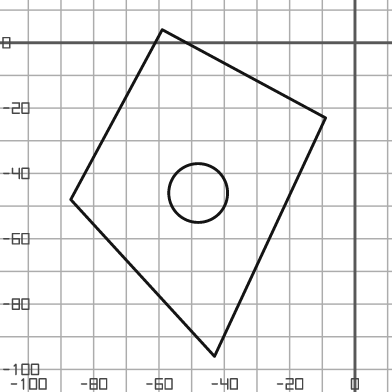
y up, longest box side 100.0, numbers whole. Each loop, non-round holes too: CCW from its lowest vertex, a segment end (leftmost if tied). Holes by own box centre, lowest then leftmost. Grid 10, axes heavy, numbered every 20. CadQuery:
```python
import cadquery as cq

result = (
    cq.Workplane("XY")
    .moveTo(-43.0, -96.0)
    .lineTo(-9.0, -23.0)
    .lineTo(-59.0, 4.0)
    .lineTo(-87.0, -48.0)
    .close()
    .moveTo(-48.0, -46.0)
    .circle(9.0)
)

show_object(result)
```